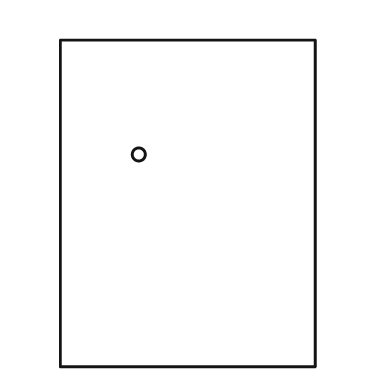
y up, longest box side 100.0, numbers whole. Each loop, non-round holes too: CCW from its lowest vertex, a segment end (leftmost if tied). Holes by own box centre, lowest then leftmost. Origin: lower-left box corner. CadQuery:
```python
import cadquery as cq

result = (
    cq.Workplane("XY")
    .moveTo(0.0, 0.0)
    .lineTo(78.0, 0.0)
    .lineTo(78.0, 100.0)
    .lineTo(0.0, 100.0)
    .close()
    .moveTo(24.0, 65.0)
    .circle(2.0)
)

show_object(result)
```